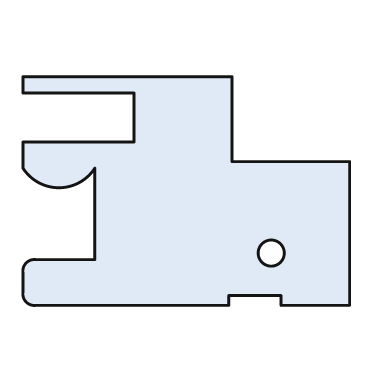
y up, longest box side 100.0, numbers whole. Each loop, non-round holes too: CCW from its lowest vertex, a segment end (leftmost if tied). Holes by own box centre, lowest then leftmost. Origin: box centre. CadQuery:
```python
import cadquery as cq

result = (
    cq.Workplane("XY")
    .moveTo(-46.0, -35.0)
    .lineTo(13.0, -35.0)
    .lineTo(13.0, -32.0)
    .lineTo(29.0, -32.0)
    .lineTo(29.0, -35.0)
    .lineTo(50.0, -35.0)
    .lineTo(50.0, 9.0)
    .lineTo(14.0, 9.0)
    .lineTo(14.0, 35.0)
    .lineTo(-50.0, 35.0)
    .lineTo(-50.0, 30.0)
    .lineTo(-16.0, 30.0)
    .lineTo(-16.0, 15.0)
    .lineTo(-50.0, 15.0)
    .lineTo(-50.0, 7.0)
    .threePointArc((-39.0, 1.0), (-28.0, 7.0))
    .lineTo(-28.0, -21.0)
    .lineTo(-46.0, -21.0)
    .threePointArc((-49.0, -22.0), (-50.0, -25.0))
    .lineTo(-50.0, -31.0)
    .threePointArc((-49.0, -34.0), (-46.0, -35.0))
    .close()
    .moveTo(26.0, -19.0)
    .circle(4.0)
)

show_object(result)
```